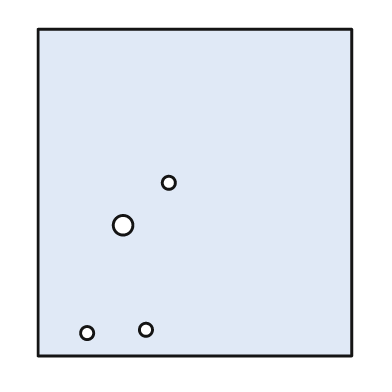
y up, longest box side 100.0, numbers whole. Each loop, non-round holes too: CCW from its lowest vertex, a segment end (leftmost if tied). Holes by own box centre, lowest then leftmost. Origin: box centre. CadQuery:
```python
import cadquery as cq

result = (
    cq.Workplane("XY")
    .moveTo(-48.0, -50.0)
    .lineTo(48.0, -50.0)
    .lineTo(48.0, 50.0)
    .lineTo(-48.0, 50.0)
    .close()
    .moveTo(-33.0, -43.0)
    .circle(2.0)
    .moveTo(-15.0, -42.0)
    .circle(2.0)
    .moveTo(-22.0, -10.0)
    .circle(3.0)
    .moveTo(-8.0, 3.0)
    .circle(2.0)
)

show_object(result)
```